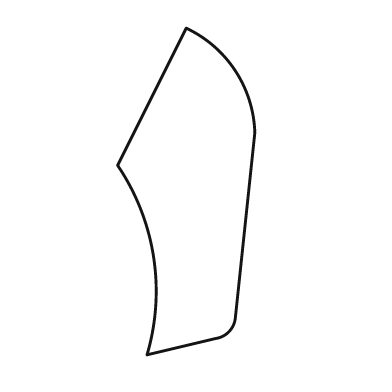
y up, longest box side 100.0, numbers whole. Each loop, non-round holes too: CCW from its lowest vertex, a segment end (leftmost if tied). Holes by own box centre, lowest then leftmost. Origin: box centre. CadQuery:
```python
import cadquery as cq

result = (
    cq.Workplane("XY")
    .moveTo(-12.0, -50.0)
    .lineTo(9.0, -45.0)
    .threePointArc((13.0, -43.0), (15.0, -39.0))
    .lineTo(21.0, 18.0)
    .threePointArc((15.0, 37.0), (0.0, 50.0))
    .lineTo(-21.0, 8.0)
    .threePointArc((-10.0, -20.0), (-12.0, -50.0))
    .close()
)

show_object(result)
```